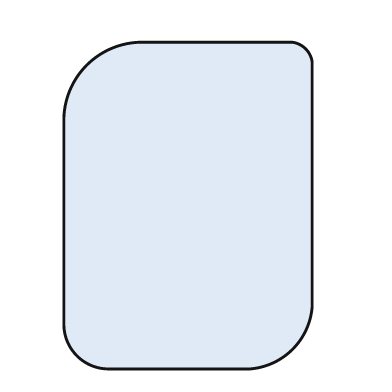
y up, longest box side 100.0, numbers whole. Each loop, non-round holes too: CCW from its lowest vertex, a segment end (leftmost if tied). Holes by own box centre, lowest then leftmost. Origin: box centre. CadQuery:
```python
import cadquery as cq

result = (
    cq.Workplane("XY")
    .moveTo(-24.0, -50.0)
    .lineTo(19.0, -50.0)
    .threePointArc((32.0, -44.0), (38.0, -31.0))
    .lineTo(38.0, 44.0)
    .threePointArc((36.0, 48.0), (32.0, 50.0))
    .lineTo(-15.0, 50.0)
    .threePointArc((-31.0, 43.0), (-38.0, 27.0))
    .lineTo(-38.0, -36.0)
    .threePointArc((-34.0, -46.0), (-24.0, -50.0))
    .close()
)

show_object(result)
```